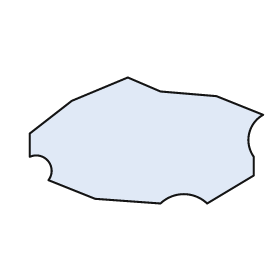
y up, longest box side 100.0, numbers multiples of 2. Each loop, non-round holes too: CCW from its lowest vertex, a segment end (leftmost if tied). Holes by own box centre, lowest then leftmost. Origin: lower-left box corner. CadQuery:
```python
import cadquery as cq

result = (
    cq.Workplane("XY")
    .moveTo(56.0, 0.0)
    .threePointArc((66.0, 4.0), (76.0, 0.0))
    .lineTo(96.0, 12.0)
    .lineTo(96.0, 20.0)
    .threePointArc((94.0, 30.0), (100.0, 38.0))
    .lineTo(80.0, 46.0)
    .lineTo(56.0, 48.0)
    .lineTo(42.0, 54.0)
    .lineTo(18.0, 44.0)
    .lineTo(0.0, 30.0)
    .lineTo(0.0, 20.0)
    .threePointArc((8.0, 18.0), (8.0, 10.0))
    .lineTo(28.0, 2.0)
    .close()
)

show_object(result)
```